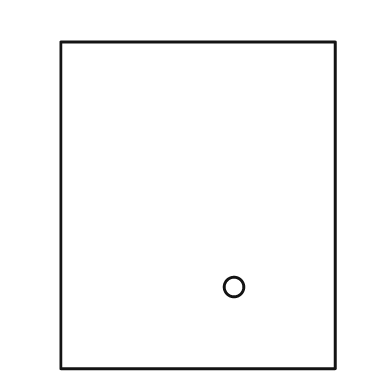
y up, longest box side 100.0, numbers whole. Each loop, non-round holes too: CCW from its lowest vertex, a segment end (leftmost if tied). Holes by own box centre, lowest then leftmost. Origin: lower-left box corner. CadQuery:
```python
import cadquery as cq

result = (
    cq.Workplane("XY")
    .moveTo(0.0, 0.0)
    .lineTo(84.0, 0.0)
    .lineTo(84.0, 100.0)
    .lineTo(0.0, 100.0)
    .close()
    .moveTo(53.0, 25.0)
    .circle(3.0)
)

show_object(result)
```